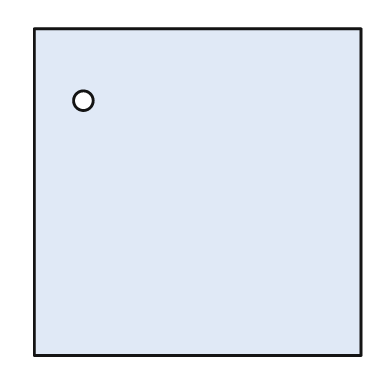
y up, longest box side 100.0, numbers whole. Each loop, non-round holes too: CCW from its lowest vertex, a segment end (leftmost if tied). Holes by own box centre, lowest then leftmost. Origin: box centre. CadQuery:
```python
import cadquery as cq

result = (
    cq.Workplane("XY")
    .moveTo(-50.0, -50.0)
    .lineTo(50.0, -50.0)
    .lineTo(50.0, 50.0)
    .lineTo(-50.0, 50.0)
    .close()
    .moveTo(-35.0, 28.0)
    .circle(3.0)
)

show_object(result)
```